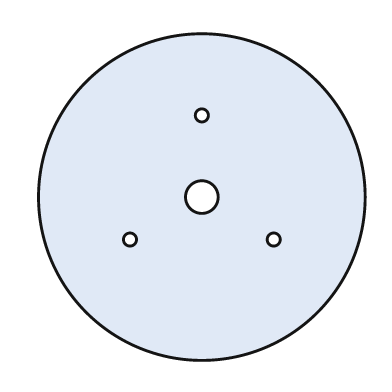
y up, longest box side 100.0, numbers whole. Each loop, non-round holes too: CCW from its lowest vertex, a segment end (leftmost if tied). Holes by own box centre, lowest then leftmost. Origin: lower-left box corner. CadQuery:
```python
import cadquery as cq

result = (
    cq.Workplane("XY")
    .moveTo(50.0, 50.0)
    .circle(50.0)
    .moveTo(28.0, 37.0)
    .circle(2.0)
    .moveTo(72.0, 37.0)
    .circle(2.0)
    .moveTo(50.0, 50.0)
    .circle(5.0)
    .moveTo(50.0, 75.0)
    .circle(2.0)
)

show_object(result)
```